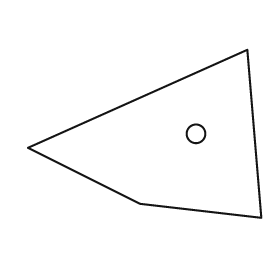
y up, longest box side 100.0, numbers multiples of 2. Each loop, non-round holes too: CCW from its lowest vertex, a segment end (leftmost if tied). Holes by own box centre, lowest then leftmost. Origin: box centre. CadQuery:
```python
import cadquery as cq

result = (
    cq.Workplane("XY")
    .moveTo(50.0, -36.0)
    .lineTo(44.0, 36.0)
    .lineTo(-50.0, -6.0)
    .lineTo(-2.0, -30.0)
    .close()
    .moveTo(22.0, 0.0)
    .circle(4.0)
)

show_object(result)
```